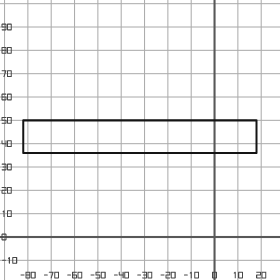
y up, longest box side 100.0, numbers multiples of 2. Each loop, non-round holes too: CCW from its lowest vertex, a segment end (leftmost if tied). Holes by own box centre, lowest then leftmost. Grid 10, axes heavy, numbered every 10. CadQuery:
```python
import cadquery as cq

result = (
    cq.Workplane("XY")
    .moveTo(-82.0, 36.0)
    .lineTo(18.0, 36.0)
    .lineTo(18.0, 50.0)
    .lineTo(-82.0, 50.0)
    .close()
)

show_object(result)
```